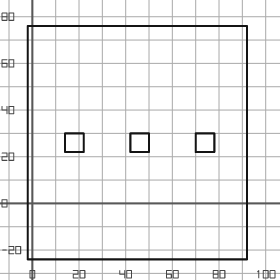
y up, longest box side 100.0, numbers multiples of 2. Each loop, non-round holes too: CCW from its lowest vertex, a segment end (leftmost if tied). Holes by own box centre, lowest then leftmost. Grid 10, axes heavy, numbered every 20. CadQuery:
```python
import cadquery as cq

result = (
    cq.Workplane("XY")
    .moveTo(-2.0, -24.0)
    .lineTo(92.0, -24.0)
    .lineTo(92.0, 76.0)
    .lineTo(-2.0, 76.0)
    .close()
    .moveTo(14.0, 22.0)
    .lineTo(22.0, 22.0)
    .lineTo(22.0, 30.0)
    .lineTo(14.0, 30.0)
    .close()
    .moveTo(42.0, 22.0)
    .lineTo(50.0, 22.0)
    .lineTo(50.0, 30.0)
    .lineTo(42.0, 30.0)
    .close()
    .moveTo(70.0, 22.0)
    .lineTo(78.0, 22.0)
    .lineTo(78.0, 30.0)
    .lineTo(70.0, 30.0)
    .close()
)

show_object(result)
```